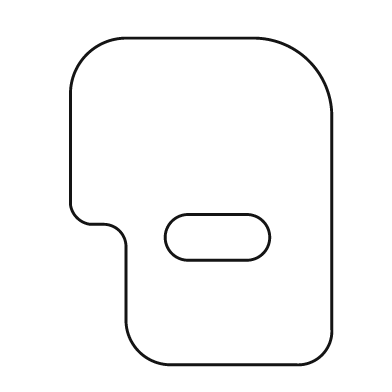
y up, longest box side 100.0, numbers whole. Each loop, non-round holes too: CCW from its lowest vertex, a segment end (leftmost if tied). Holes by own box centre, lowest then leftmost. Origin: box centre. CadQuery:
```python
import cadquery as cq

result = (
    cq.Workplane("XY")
    .moveTo(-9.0, -50.0)
    .lineTo(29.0, -50.0)
    .threePointArc((37.0, -47.0), (40.0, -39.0))
    .lineTo(40.0, 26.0)
    .threePointArc((33.0, 43.0), (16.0, 50.0))
    .lineTo(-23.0, 50.0)
    .threePointArc((-35.0, 45.0), (-40.0, 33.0))
    .lineTo(-40.0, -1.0)
    .threePointArc((-38.0, -5.0), (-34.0, -7.0))
    .lineTo(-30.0, -7.0)
    .threePointArc((-25.0, -9.0), (-23.0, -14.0))
    .lineTo(-23.0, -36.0)
    .threePointArc((-19.0, -46.0), (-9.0, -50.0))
    .close()
    .moveTo(-4.0, -18.0)
    .lineTo(14.0, -18.0)
    .threePointArc((21.0, -11.0), (14.0, -4.0))
    .lineTo(-4.0, -4.0)
    .threePointArc((-11.0, -11.0), (-4.0, -18.0))
    .close()
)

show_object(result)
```